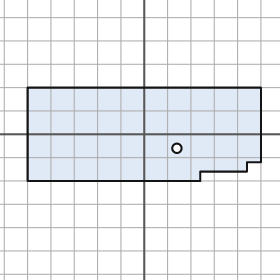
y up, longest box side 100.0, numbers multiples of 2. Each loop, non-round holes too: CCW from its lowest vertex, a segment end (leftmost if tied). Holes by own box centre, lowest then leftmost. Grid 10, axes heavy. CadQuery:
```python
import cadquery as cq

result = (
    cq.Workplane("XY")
    .moveTo(-50.0, -20.0)
    .lineTo(24.0, -20.0)
    .lineTo(24.0, -16.0)
    .lineTo(44.0, -16.0)
    .lineTo(44.0, -12.0)
    .lineTo(50.0, -12.0)
    .lineTo(50.0, 20.0)
    .lineTo(-50.0, 20.0)
    .close()
    .moveTo(14.0, -6.0)
    .circle(2.0)
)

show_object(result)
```